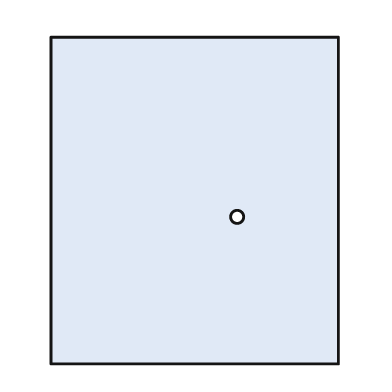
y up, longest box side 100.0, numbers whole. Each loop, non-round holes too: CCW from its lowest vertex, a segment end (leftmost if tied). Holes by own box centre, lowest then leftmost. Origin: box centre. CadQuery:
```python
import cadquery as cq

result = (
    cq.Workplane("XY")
    .moveTo(-44.0, -50.0)
    .lineTo(44.0, -50.0)
    .lineTo(44.0, 50.0)
    .lineTo(-44.0, 50.0)
    .close()
    .moveTo(13.0, -5.0)
    .circle(2.0)
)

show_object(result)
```